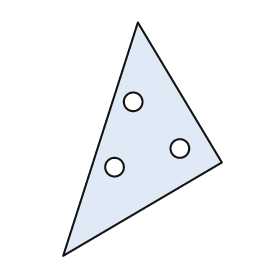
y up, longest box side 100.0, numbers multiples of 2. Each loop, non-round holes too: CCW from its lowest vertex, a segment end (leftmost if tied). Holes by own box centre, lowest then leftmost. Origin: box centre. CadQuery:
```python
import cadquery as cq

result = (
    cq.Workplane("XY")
    .moveTo(-34.0, -50.0)
    .lineTo(34.0, -10.0)
    .lineTo(-2.0, 50.0)
    .close()
    .moveTo(-12.0, -12.0)
    .circle(4.0)
    .moveTo(16.0, -4.0)
    .circle(4.0)
    .moveTo(-4.0, 16.0)
    .circle(4.0)
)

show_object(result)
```